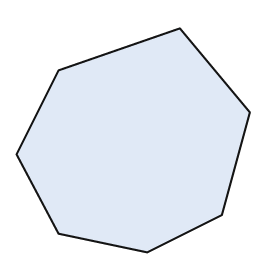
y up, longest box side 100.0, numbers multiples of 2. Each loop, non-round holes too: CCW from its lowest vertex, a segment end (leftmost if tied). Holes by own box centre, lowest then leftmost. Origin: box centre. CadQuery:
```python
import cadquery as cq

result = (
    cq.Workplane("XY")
    .moveTo(6.0, -48.0)
    .lineTo(38.0, -32.0)
    .lineTo(50.0, 12.0)
    .lineTo(20.0, 48.0)
    .lineTo(-32.0, 30.0)
    .lineTo(-50.0, -6.0)
    .lineTo(-32.0, -40.0)
    .close()
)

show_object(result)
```